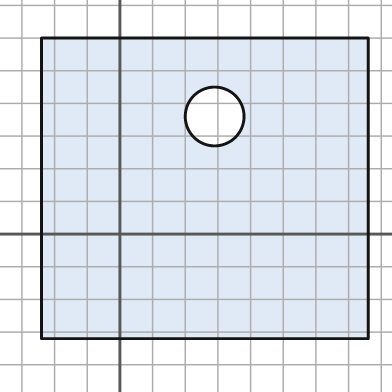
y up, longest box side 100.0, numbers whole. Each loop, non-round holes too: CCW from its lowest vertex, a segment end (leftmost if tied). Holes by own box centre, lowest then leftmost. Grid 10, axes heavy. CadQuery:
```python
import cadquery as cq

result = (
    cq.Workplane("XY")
    .moveTo(-24.0, -32.0)
    .lineTo(76.0, -32.0)
    .lineTo(76.0, 60.0)
    .lineTo(-24.0, 60.0)
    .close()
    .moveTo(29.0, 36.0)
    .circle(9.0)
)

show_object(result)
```